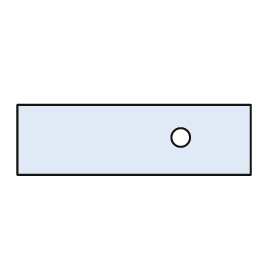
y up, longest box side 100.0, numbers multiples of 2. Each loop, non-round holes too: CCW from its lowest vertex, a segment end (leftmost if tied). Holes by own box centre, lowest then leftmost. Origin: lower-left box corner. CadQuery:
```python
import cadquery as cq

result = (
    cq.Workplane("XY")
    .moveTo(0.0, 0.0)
    .lineTo(100.0, 0.0)
    .lineTo(100.0, 30.0)
    .lineTo(0.0, 30.0)
    .close()
    .moveTo(70.0, 16.0)
    .circle(4.0)
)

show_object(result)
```